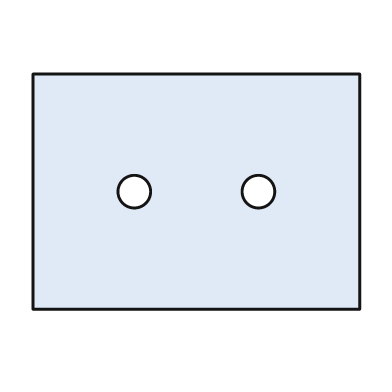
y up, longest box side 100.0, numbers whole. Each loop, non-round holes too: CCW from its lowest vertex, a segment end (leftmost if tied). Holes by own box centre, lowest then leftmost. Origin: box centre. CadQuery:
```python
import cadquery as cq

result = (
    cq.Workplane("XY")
    .moveTo(-50.0, -36.0)
    .lineTo(50.0, -36.0)
    .lineTo(50.0, 36.0)
    .lineTo(-50.0, 36.0)
    .close()
    .moveTo(-19.0, 0.0)
    .circle(5.0)
    .moveTo(19.0, 0.0)
    .circle(5.0)
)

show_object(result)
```